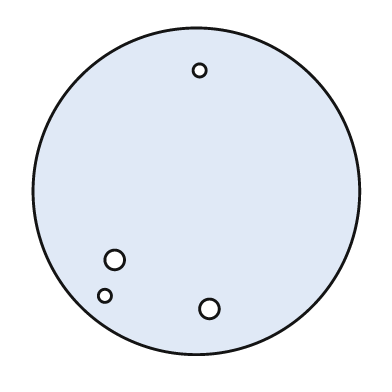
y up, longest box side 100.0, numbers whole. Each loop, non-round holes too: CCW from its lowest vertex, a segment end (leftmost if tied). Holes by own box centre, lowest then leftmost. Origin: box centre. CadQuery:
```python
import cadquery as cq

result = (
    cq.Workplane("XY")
    .moveTo(0.0, 0.0)
    .circle(50.0)
    .moveTo(4.0, -36.0)
    .circle(3.0)
    .moveTo(-28.0, -32.0)
    .circle(2.0)
    .moveTo(-25.0, -21.0)
    .circle(3.0)
    .moveTo(1.0, 37.0)
    .circle(2.0)
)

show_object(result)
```